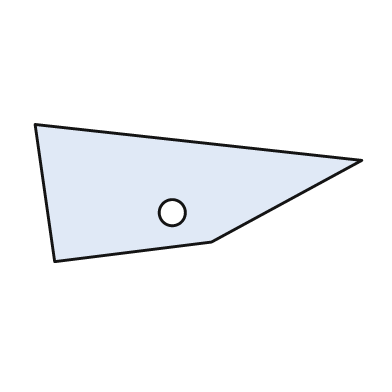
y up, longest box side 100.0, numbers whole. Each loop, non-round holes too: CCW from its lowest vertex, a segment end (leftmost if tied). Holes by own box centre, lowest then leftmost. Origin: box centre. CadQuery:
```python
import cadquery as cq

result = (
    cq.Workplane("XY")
    .moveTo(-44.0, -21.0)
    .lineTo(4.0, -15.0)
    .lineTo(50.0, 10.0)
    .lineTo(-50.0, 21.0)
    .close()
    .moveTo(-8.0, -6.0)
    .circle(4.0)
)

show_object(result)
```